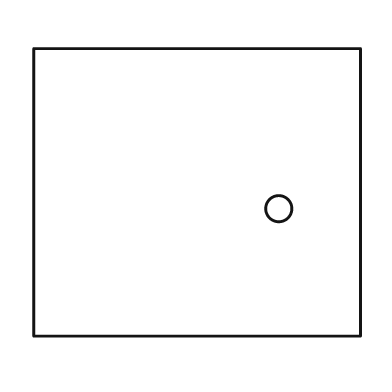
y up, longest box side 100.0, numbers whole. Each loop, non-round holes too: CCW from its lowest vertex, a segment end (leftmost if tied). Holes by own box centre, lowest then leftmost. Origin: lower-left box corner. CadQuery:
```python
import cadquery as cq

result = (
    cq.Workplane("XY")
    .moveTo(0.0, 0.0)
    .lineTo(100.0, 0.0)
    .lineTo(100.0, 88.0)
    .lineTo(0.0, 88.0)
    .close()
    .moveTo(75.0, 39.0)
    .circle(4.0)
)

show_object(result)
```